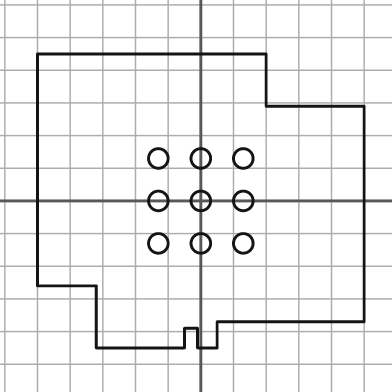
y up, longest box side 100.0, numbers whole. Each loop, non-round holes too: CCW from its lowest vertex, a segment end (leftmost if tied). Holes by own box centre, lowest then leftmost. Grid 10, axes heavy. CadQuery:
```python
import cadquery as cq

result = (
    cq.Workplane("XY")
    .moveTo(-32.0, -45.0)
    .lineTo(-5.0, -45.0)
    .lineTo(-5.0, -39.0)
    .lineTo(-1.0, -39.0)
    .lineTo(-1.0, -45.0)
    .lineTo(5.0, -45.0)
    .lineTo(5.0, -37.0)
    .lineTo(50.0, -37.0)
    .lineTo(50.0, 29.0)
    .lineTo(20.0, 29.0)
    .lineTo(20.0, 45.0)
    .lineTo(-50.0, 45.0)
    .lineTo(-50.0, -26.0)
    .lineTo(-32.0, -26.0)
    .close()
    .moveTo(-13.0, -13.0)
    .circle(3.0)
    .moveTo(0.0, -13.0)
    .circle(3.0)
    .moveTo(13.0, -13.0)
    .circle(3.0)
    .moveTo(-13.0, 0.0)
    .circle(3.0)
    .moveTo(0.0, 0.0)
    .circle(3.0)
    .moveTo(13.0, 0.0)
    .circle(3.0)
    .moveTo(-13.0, 13.0)
    .circle(3.0)
    .moveTo(0.0, 13.0)
    .circle(3.0)
    .moveTo(13.0, 13.0)
    .circle(3.0)
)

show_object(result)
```